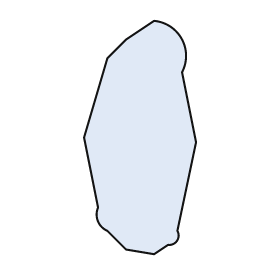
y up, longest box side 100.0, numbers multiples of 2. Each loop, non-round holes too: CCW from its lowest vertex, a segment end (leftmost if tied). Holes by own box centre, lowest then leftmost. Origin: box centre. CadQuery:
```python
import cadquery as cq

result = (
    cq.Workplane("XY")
    .moveTo(6.0, -50.0)
    .lineTo(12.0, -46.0)
    .threePointArc((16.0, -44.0), (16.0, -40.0))
    .lineTo(24.0, -2.0)
    .lineTo(18.0, 28.0)
    .threePointArc((18.0, 42.0), (6.0, 50.0))
    .lineTo(-6.0, 42.0)
    .lineTo(-14.0, 34.0)
    .lineTo(-24.0, 0.0)
    .lineTo(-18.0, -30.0)
    .threePointArc((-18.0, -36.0), (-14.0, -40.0))
    .lineTo(-6.0, -48.0)
    .close()
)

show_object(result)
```